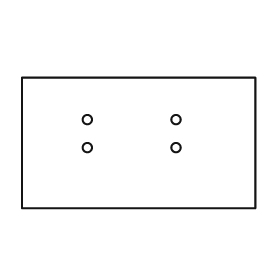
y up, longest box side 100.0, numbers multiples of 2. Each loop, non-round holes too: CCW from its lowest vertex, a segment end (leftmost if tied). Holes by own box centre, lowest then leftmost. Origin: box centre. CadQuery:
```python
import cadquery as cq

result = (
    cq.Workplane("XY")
    .moveTo(-50.0, -28.0)
    .lineTo(50.0, -28.0)
    .lineTo(50.0, 28.0)
    .lineTo(-50.0, 28.0)
    .close()
    .moveTo(-22.0, -2.0)
    .circle(2.0)
    .moveTo(16.0, -2.0)
    .circle(2.0)
    .moveTo(-22.0, 10.0)
    .circle(2.0)
    .moveTo(16.0, 10.0)
    .circle(2.0)
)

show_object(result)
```